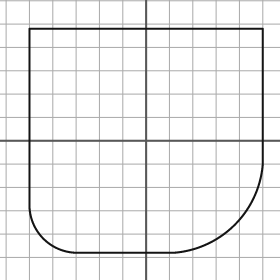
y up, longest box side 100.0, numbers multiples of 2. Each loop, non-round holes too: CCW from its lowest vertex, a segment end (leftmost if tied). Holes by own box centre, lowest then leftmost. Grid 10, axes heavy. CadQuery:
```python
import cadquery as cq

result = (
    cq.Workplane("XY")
    .moveTo(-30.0, -48.0)
    .lineTo(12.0, -48.0)
    .threePointArc((38.0, -36.0), (50.0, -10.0))
    .lineTo(50.0, 48.0)
    .lineTo(-50.0, 48.0)
    .lineTo(-50.0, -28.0)
    .threePointArc((-44.0, -42.0), (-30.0, -48.0))
    .close()
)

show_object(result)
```